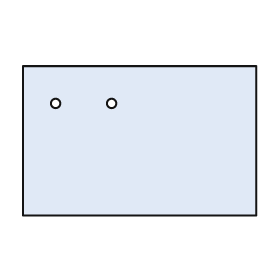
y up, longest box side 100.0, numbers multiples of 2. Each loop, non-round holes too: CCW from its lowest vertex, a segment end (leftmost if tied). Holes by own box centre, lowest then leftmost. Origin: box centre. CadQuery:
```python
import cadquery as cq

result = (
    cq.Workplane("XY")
    .moveTo(-50.0, -32.0)
    .lineTo(50.0, -32.0)
    .lineTo(50.0, 32.0)
    .lineTo(-50.0, 32.0)
    .close()
    .moveTo(-36.0, 16.0)
    .circle(2.0)
    .moveTo(-12.0, 16.0)
    .circle(2.0)
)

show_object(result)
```